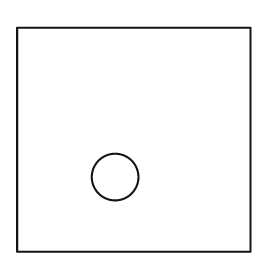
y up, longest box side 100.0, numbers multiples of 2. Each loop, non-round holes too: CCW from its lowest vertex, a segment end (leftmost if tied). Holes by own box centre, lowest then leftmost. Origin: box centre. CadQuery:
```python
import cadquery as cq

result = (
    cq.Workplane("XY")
    .moveTo(-50.0, -48.0)
    .lineTo(50.0, -48.0)
    .lineTo(50.0, 48.0)
    .lineTo(-50.0, 48.0)
    .close()
    .moveTo(-8.0, -16.0)
    .circle(10.0)
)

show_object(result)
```